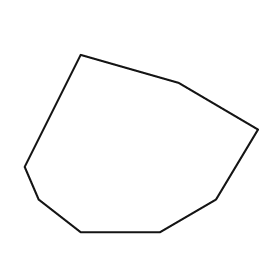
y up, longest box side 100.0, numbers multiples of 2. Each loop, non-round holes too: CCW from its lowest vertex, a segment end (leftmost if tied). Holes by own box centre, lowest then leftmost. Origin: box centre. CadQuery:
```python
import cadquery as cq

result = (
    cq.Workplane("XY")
    .moveTo(-26.0, -38.0)
    .lineTo(8.0, -38.0)
    .lineTo(32.0, -24.0)
    .lineTo(50.0, 6.0)
    .lineTo(16.0, 26.0)
    .lineTo(-26.0, 38.0)
    .lineTo(-50.0, -10.0)
    .lineTo(-44.0, -24.0)
    .close()
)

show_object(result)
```